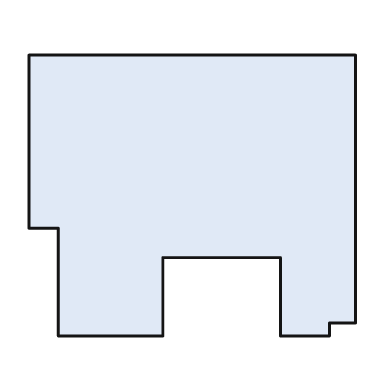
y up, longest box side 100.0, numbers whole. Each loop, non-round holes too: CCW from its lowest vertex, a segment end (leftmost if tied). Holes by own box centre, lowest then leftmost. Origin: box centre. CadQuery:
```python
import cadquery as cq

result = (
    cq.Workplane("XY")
    .moveTo(-41.0, -43.0)
    .lineTo(-9.0, -43.0)
    .lineTo(-9.0, -19.0)
    .lineTo(27.0, -19.0)
    .lineTo(27.0, -43.0)
    .lineTo(42.0, -43.0)
    .lineTo(42.0, -39.0)
    .lineTo(50.0, -39.0)
    .lineTo(50.0, 43.0)
    .lineTo(-50.0, 43.0)
    .lineTo(-50.0, -10.0)
    .lineTo(-41.0, -10.0)
    .close()
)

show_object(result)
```